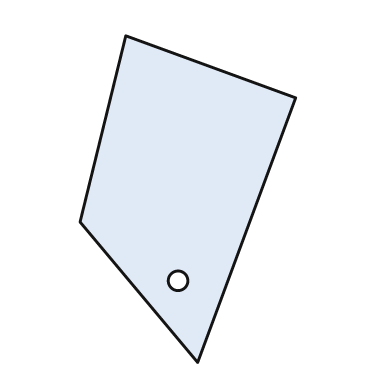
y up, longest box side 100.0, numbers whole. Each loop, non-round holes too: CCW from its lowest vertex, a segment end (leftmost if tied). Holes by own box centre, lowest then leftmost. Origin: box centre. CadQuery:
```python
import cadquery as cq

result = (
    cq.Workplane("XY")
    .moveTo(3.0, -50.0)
    .lineTo(33.0, 31.0)
    .lineTo(-19.0, 50.0)
    .lineTo(-33.0, -7.0)
    .close()
    .moveTo(-3.0, -25.0)
    .circle(3.0)
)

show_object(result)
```